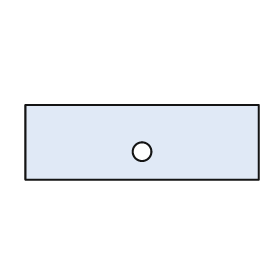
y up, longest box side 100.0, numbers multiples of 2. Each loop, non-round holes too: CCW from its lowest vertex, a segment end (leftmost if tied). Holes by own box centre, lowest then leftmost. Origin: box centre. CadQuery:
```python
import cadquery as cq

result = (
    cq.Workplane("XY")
    .moveTo(-50.0, -16.0)
    .lineTo(50.0, -16.0)
    .lineTo(50.0, 16.0)
    .lineTo(-50.0, 16.0)
    .close()
    .moveTo(0.0, -4.0)
    .circle(4.0)
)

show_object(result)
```